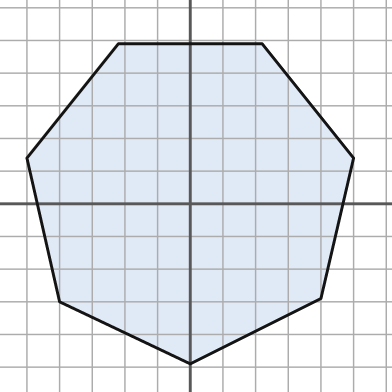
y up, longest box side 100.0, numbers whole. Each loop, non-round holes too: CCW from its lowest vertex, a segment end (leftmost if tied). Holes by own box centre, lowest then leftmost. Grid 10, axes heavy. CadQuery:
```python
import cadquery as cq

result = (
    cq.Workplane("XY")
    .moveTo(0.0, -49.0)
    .lineTo(40.0, -29.0)
    .lineTo(50.0, 14.0)
    .lineTo(22.0, 49.0)
    .lineTo(-22.0, 49.0)
    .lineTo(-50.0, 14.0)
    .lineTo(-40.0, -30.0)
    .close()
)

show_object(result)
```